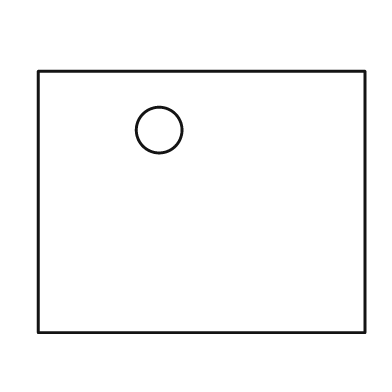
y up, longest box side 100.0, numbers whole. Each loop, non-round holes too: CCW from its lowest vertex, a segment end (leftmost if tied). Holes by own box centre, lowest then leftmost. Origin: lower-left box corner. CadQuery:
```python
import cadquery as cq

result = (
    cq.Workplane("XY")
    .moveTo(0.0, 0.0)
    .lineTo(100.0, 0.0)
    .lineTo(100.0, 80.0)
    .lineTo(0.0, 80.0)
    .close()
    .moveTo(37.0, 62.0)
    .circle(7.0)
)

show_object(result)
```